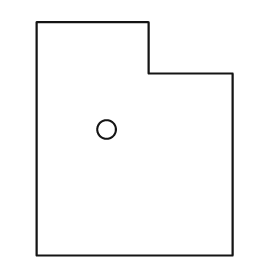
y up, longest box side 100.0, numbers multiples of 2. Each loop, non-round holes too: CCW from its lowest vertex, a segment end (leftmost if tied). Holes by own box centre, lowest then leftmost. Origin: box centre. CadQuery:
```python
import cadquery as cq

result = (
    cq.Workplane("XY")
    .moveTo(-42.0, -50.0)
    .lineTo(42.0, -50.0)
    .lineTo(42.0, 28.0)
    .lineTo(6.0, 28.0)
    .lineTo(6.0, 50.0)
    .lineTo(-42.0, 50.0)
    .close()
    .moveTo(-12.0, 4.0)
    .circle(4.0)
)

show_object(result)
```